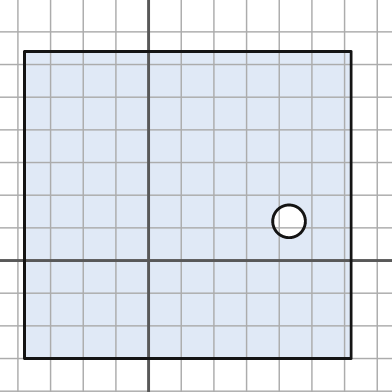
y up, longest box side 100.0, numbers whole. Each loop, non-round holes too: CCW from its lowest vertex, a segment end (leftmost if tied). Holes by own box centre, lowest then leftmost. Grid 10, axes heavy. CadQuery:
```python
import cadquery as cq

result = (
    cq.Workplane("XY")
    .moveTo(-38.0, -30.0)
    .lineTo(62.0, -30.0)
    .lineTo(62.0, 64.0)
    .lineTo(-38.0, 64.0)
    .close()
    .moveTo(43.0, 12.0)
    .circle(5.0)
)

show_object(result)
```